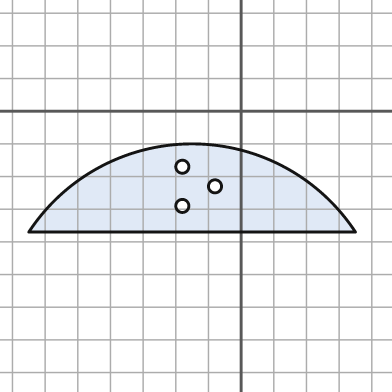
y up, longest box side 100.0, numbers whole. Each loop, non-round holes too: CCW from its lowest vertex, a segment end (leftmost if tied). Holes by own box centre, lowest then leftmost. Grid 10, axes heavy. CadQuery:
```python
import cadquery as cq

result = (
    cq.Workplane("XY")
    .moveTo(-65.0, -37.0)
    .lineTo(35.0, -37.0)
    .threePointArc((-15.0, -10.0), (-65.0, -37.0))
    .close()
    .moveTo(-18.0, -29.0)
    .circle(2.0)
    .moveTo(-8.0, -23.0)
    .circle(2.0)
    .moveTo(-18.0, -17.0)
    .circle(2.0)
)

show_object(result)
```